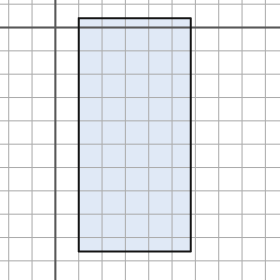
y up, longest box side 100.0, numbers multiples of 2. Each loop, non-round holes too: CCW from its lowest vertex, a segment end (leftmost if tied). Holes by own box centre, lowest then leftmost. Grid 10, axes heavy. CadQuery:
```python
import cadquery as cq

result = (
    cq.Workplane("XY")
    .moveTo(10.0, -96.0)
    .lineTo(58.0, -96.0)
    .lineTo(58.0, 4.0)
    .lineTo(10.0, 4.0)
    .close()
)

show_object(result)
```